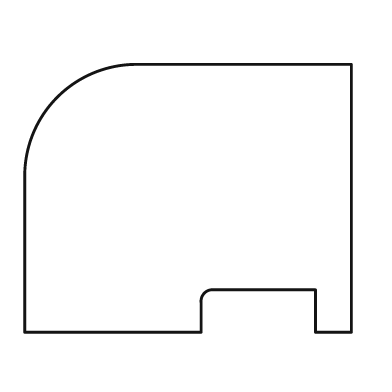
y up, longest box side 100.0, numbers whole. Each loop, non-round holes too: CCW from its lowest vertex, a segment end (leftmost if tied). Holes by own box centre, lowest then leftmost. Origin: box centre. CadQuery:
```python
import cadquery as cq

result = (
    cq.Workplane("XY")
    .moveTo(-50.0, -41.0)
    .lineTo(4.0, -41.0)
    .lineTo(4.0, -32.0)
    .threePointArc((5.0, -29.0), (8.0, -28.0))
    .lineTo(39.0, -28.0)
    .lineTo(39.0, -41.0)
    .lineTo(50.0, -41.0)
    .lineTo(50.0, 41.0)
    .lineTo(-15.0, 41.0)
    .threePointArc((-40.0, 31.0), (-50.0, 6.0))
    .close()
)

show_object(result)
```